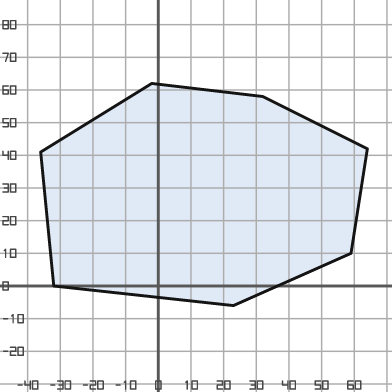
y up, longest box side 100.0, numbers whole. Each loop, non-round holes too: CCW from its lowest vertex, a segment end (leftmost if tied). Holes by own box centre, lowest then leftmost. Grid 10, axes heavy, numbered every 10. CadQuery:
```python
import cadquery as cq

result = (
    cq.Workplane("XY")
    .moveTo(23.0, -6.0)
    .lineTo(59.0, 10.0)
    .lineTo(64.0, 42.0)
    .lineTo(32.0, 58.0)
    .lineTo(-2.0, 62.0)
    .lineTo(-36.0, 41.0)
    .lineTo(-32.0, 0.0)
    .close()
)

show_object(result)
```